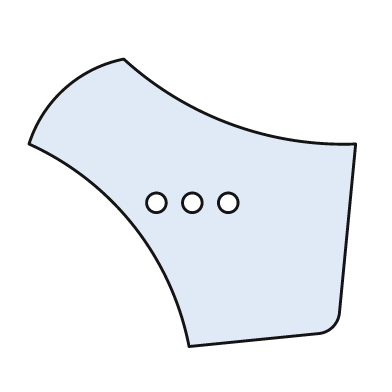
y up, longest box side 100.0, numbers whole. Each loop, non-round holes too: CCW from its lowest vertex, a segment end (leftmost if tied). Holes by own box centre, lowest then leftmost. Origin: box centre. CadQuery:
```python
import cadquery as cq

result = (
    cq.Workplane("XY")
    .moveTo(-1.0, -44.0)
    .lineTo(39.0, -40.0)
    .threePointArc((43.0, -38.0), (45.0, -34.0))
    .lineTo(50.0, 18.0)
    .threePointArc((12.0, 24.0), (-21.0, 44.0))
    .threePointArc((-39.0, 35.0), (-50.0, 18.0))
    .threePointArc((-18.0, -7.0), (-1.0, -44.0))
    .close()
    .moveTo(-11.0, 0.0)
    .circle(3.0)
    .moveTo(0.0, 0.0)
    .circle(3.0)
    .moveTo(11.0, 0.0)
    .circle(3.0)
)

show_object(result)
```